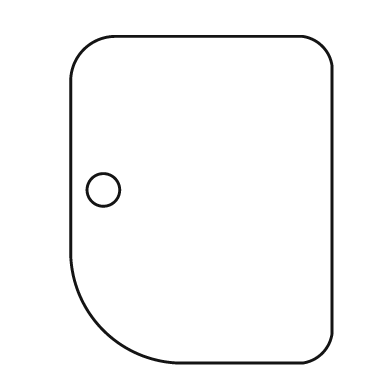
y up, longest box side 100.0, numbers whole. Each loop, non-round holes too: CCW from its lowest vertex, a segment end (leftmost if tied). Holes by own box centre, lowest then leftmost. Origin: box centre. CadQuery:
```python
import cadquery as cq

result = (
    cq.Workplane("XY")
    .moveTo(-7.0, -50.0)
    .lineTo(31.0, -50.0)
    .threePointArc((37.0, -47.0), (40.0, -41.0))
    .lineTo(40.0, 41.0)
    .threePointArc((37.0, 47.0), (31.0, 50.0))
    .lineTo(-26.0, 50.0)
    .threePointArc((-36.0, 46.0), (-40.0, 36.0))
    .lineTo(-40.0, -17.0)
    .threePointArc((-30.0, -40.0), (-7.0, -50.0))
    .close()
    .moveTo(-30.0, 3.0)
    .circle(5.0)
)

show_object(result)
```